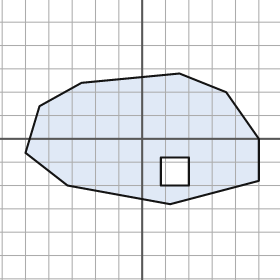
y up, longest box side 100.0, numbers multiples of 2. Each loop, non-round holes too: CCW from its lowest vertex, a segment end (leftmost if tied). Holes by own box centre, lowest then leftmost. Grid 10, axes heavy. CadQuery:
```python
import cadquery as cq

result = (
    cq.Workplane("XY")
    .moveTo(12.0, -28.0)
    .lineTo(50.0, -18.0)
    .lineTo(50.0, 0.0)
    .lineTo(36.0, 20.0)
    .lineTo(16.0, 28.0)
    .lineTo(-26.0, 24.0)
    .lineTo(-44.0, 14.0)
    .lineTo(-50.0, -6.0)
    .lineTo(-32.0, -20.0)
    .close()
    .moveTo(8.0, -20.0)
    .lineTo(20.0, -20.0)
    .lineTo(20.0, -8.0)
    .lineTo(8.0, -8.0)
    .close()
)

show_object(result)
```